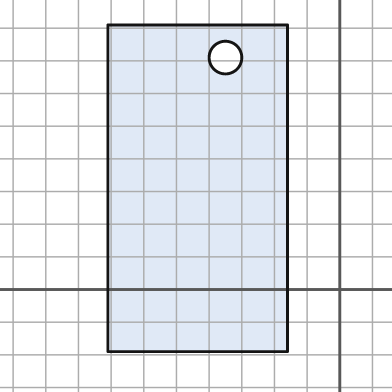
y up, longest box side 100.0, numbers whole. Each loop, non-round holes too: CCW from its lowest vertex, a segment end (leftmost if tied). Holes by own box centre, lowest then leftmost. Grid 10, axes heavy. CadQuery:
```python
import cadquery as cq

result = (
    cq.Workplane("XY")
    .moveTo(-71.0, -19.0)
    .lineTo(-16.0, -19.0)
    .lineTo(-16.0, 81.0)
    .lineTo(-71.0, 81.0)
    .close()
    .moveTo(-35.0, 71.0)
    .circle(5.0)
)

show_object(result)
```